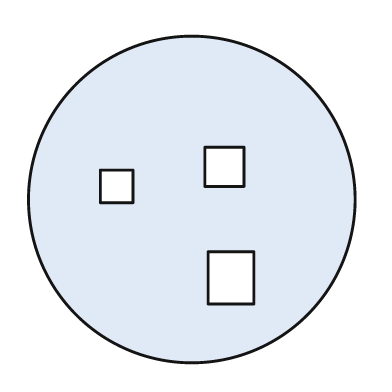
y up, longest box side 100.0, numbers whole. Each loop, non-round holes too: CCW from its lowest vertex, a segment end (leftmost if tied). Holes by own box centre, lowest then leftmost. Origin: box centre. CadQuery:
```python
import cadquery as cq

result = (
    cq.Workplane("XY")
    .moveTo(0.0, 0.0)
    .circle(50.0)
    .moveTo(5.0, -32.0)
    .lineTo(19.0, -32.0)
    .lineTo(19.0, -16.0)
    .lineTo(5.0, -16.0)
    .close()
    .moveTo(-28.0, -1.0)
    .lineTo(-18.0, -1.0)
    .lineTo(-18.0, 9.0)
    .lineTo(-28.0, 9.0)
    .close()
    .moveTo(4.0, 4.0)
    .lineTo(16.0, 4.0)
    .lineTo(16.0, 16.0)
    .lineTo(4.0, 16.0)
    .close()
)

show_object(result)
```